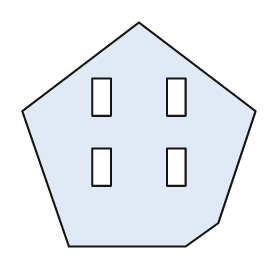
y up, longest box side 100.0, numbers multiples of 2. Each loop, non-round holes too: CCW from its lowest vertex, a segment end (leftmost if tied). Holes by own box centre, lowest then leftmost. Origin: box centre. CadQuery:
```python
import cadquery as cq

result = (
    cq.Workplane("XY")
    .moveTo(-30.0, -48.0)
    .lineTo(20.0, -48.0)
    .lineTo(34.0, -38.0)
    .lineTo(50.0, 10.0)
    .lineTo(0.0, 48.0)
    .lineTo(-50.0, 10.0)
    .close()
    .moveTo(-20.0, -22.0)
    .lineTo(-12.0, -22.0)
    .lineTo(-12.0, -6.0)
    .lineTo(-20.0, -6.0)
    .close()
    .moveTo(12.0, -22.0)
    .lineTo(20.0, -22.0)
    .lineTo(20.0, -6.0)
    .lineTo(12.0, -6.0)
    .close()
    .moveTo(-20.0, 8.0)
    .lineTo(-12.0, 8.0)
    .lineTo(-12.0, 24.0)
    .lineTo(-20.0, 24.0)
    .close()
    .moveTo(12.0, 8.0)
    .lineTo(20.0, 8.0)
    .lineTo(20.0, 24.0)
    .lineTo(12.0, 24.0)
    .close()
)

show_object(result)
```